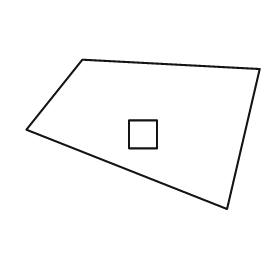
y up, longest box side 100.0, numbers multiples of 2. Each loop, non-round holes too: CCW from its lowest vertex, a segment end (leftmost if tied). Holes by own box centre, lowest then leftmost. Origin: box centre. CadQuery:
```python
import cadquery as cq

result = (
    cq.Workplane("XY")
    .moveTo(36.0, -32.0)
    .lineTo(50.0, 28.0)
    .lineTo(-26.0, 32.0)
    .lineTo(-50.0, 2.0)
    .close()
    .moveTo(-6.0, -6.0)
    .lineTo(6.0, -6.0)
    .lineTo(6.0, 6.0)
    .lineTo(-6.0, 6.0)
    .close()
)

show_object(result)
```